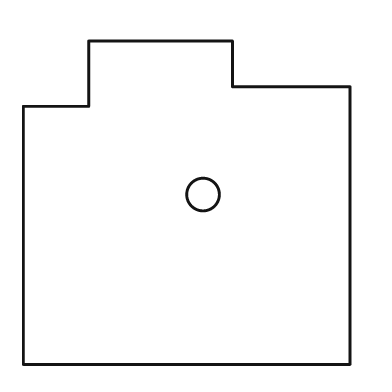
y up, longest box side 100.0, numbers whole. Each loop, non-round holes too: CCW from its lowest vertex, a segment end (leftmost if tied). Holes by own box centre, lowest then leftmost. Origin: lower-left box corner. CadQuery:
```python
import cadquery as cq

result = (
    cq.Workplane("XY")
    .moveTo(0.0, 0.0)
    .lineTo(100.0, 0.0)
    .lineTo(100.0, 85.0)
    .lineTo(64.0, 85.0)
    .lineTo(64.0, 99.0)
    .lineTo(20.0, 99.0)
    .lineTo(20.0, 79.0)
    .lineTo(0.0, 79.0)
    .close()
    .moveTo(55.0, 52.0)
    .circle(5.0)
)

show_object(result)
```